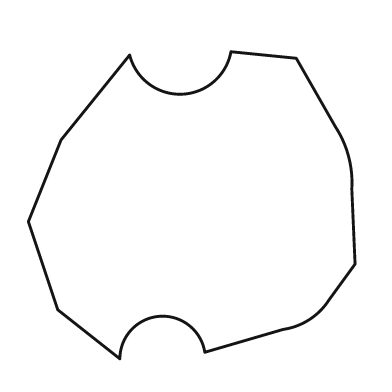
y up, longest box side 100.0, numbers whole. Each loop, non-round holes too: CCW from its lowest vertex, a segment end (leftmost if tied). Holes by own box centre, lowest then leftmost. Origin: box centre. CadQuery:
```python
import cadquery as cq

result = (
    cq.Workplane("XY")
    .moveTo(-22.0, -47.0)
    .threePointArc((-10.0, -34.0), (4.0, -45.0))
    .lineTo(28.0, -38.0)
    .threePointArc((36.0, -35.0), (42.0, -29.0))
    .lineTo(50.0, -18.0)
    .lineTo(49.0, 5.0)
    .threePointArc((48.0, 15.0), (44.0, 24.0))
    .lineTo(32.0, 45.0)
    .lineTo(12.0, 47.0)
    .threePointArc((-3.0, 34.0), (-19.0, 46.0))
    .lineTo(-40.0, 20.0)
    .lineTo(-50.0, -5.0)
    .lineTo(-41.0, -32.0)
    .close()
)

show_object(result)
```